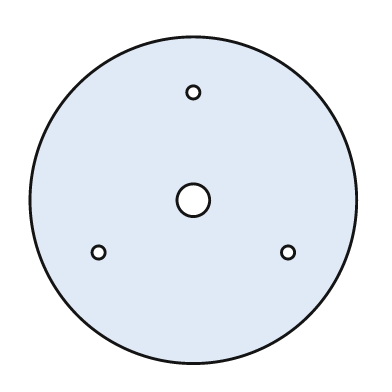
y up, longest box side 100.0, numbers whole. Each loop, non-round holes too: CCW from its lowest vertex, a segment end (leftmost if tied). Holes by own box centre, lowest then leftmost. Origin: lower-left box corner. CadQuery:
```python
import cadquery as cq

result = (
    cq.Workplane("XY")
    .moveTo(50.0, 50.0)
    .circle(50.0)
    .moveTo(21.0, 34.0)
    .circle(2.0)
    .moveTo(79.0, 34.0)
    .circle(2.0)
    .moveTo(50.0, 50.0)
    .circle(5.0)
    .moveTo(50.0, 83.0)
    .circle(2.0)
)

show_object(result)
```